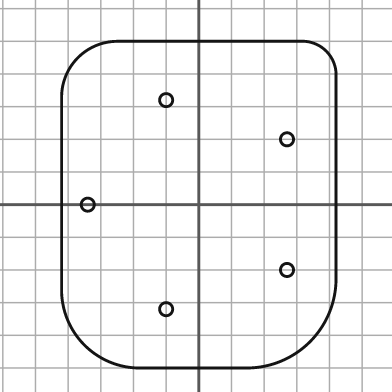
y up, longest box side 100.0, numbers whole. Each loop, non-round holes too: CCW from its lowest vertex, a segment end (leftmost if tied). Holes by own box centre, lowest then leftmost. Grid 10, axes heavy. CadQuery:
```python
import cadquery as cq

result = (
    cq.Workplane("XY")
    .moveTo(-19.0, -50.0)
    .lineTo(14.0, -50.0)
    .threePointArc((34.0, -42.0), (42.0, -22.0))
    .lineTo(42.0, 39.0)
    .threePointArc((39.0, 47.0), (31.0, 50.0))
    .lineTo(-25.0, 50.0)
    .threePointArc((-37.0, 45.0), (-42.0, 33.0))
    .lineTo(-42.0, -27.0)
    .threePointArc((-35.0, -43.0), (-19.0, -50.0))
    .close()
    .moveTo(-10.0, -32.0)
    .circle(2.0)
    .moveTo(27.0, -20.0)
    .circle(2.0)
    .moveTo(-34.0, 0.0)
    .circle(2.0)
    .moveTo(27.0, 20.0)
    .circle(2.0)
    .moveTo(-10.0, 32.0)
    .circle(2.0)
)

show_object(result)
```